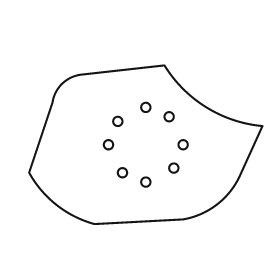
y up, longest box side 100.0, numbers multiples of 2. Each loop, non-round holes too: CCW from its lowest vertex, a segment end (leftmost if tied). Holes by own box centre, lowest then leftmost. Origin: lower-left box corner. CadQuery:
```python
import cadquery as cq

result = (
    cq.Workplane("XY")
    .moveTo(28.0, 0.0)
    .lineTo(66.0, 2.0)
    .threePointArc((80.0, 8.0), (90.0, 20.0))
    .lineTo(100.0, 42.0)
    .threePointArc((76.0, 50.0), (58.0, 68.0))
    .lineTo(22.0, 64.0)
    .threePointArc((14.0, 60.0), (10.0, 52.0))
    .lineTo(0.0, 22.0)
    .threePointArc((12.0, 8.0), (28.0, 0.0))
    .close()
    .moveTo(50.0, 18.0)
    .circle(2.0)
    .moveTo(40.0, 22.0)
    .circle(2.0)
    .moveTo(62.0, 24.0)
    .circle(2.0)
    .moveTo(34.0, 34.0)
    .circle(2.0)
    .moveTo(66.0, 34.0)
    .circle(2.0)
    .moveTo(38.0, 44.0)
    .circle(2.0)
    .moveTo(60.0, 46.0)
    .circle(2.0)
    .moveTo(50.0, 50.0)
    .circle(2.0)
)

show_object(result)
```